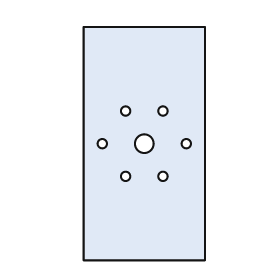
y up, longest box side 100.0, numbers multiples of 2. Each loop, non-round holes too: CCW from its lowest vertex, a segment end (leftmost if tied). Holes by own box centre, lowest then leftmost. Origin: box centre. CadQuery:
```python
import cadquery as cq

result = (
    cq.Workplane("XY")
    .moveTo(-26.0, -50.0)
    .lineTo(26.0, -50.0)
    .lineTo(26.0, 50.0)
    .lineTo(-26.0, 50.0)
    .close()
    .moveTo(-8.0, -14.0)
    .circle(2.0)
    .moveTo(8.0, -14.0)
    .circle(2.0)
    .moveTo(-18.0, 0.0)
    .circle(2.0)
    .moveTo(0.0, 0.0)
    .circle(4.0)
    .moveTo(18.0, 0.0)
    .circle(2.0)
    .moveTo(-8.0, 14.0)
    .circle(2.0)
    .moveTo(8.0, 14.0)
    .circle(2.0)
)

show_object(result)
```